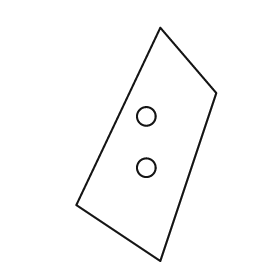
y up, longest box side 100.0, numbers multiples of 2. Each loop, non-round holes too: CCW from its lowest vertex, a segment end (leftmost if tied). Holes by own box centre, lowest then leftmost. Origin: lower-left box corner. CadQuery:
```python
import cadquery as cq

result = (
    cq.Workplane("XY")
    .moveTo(36.0, 0.0)
    .lineTo(60.0, 72.0)
    .lineTo(36.0, 100.0)
    .lineTo(0.0, 24.0)
    .close()
    .moveTo(30.0, 40.0)
    .circle(4.0)
    .moveTo(30.0, 62.0)
    .circle(4.0)
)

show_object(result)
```